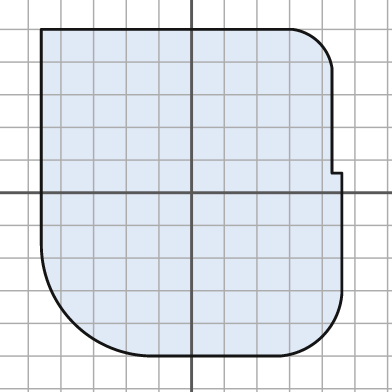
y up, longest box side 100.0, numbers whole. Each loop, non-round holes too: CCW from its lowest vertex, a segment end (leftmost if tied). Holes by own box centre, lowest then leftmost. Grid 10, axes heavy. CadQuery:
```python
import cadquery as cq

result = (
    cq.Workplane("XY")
    .moveTo(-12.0, -50.0)
    .lineTo(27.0, -50.0)
    .threePointArc((40.0, -44.0), (46.0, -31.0))
    .lineTo(46.0, 6.0)
    .lineTo(43.0, 6.0)
    .lineTo(43.0, 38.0)
    .threePointArc((39.0, 46.0), (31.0, 50.0))
    .lineTo(-46.0, 50.0)
    .lineTo(-46.0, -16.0)
    .threePointArc((-36.0, -40.0), (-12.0, -50.0))
    .close()
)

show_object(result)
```